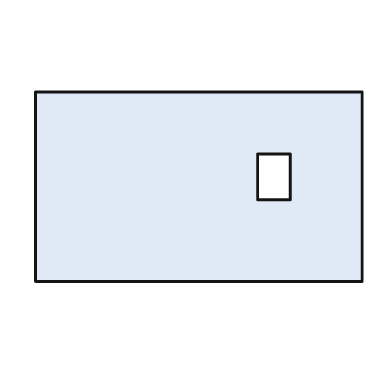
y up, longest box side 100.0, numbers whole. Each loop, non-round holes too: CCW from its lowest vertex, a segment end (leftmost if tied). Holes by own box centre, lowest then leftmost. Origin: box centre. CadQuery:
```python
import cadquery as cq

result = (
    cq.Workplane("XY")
    .moveTo(-50.0, -29.0)
    .lineTo(50.0, -29.0)
    .lineTo(50.0, 29.0)
    .lineTo(-50.0, 29.0)
    .close()
    .moveTo(18.0, -4.0)
    .lineTo(28.0, -4.0)
    .lineTo(28.0, 10.0)
    .lineTo(18.0, 10.0)
    .close()
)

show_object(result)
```